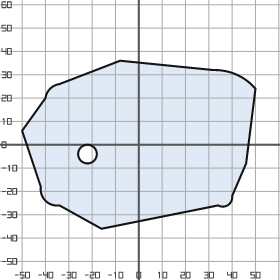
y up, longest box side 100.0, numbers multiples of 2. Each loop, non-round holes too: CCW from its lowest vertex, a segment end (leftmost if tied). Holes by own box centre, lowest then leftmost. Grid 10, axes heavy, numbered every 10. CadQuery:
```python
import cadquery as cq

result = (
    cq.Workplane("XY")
    .moveTo(-16.0, -36.0)
    .lineTo(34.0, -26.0)
    .threePointArc((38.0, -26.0), (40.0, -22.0))
    .lineTo(46.0, -8.0)
    .lineTo(50.0, 24.0)
    .threePointArc((42.0, 30.0), (32.0, 32.0))
    .lineTo(-8.0, 36.0)
    .lineTo(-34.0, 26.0)
    .threePointArc((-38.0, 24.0), (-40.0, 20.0))
    .lineTo(-50.0, 6.0)
    .lineTo(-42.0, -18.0)
    .threePointArc((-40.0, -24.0), (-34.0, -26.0))
    .close()
    .moveTo(-22.0, -4.0)
    .circle(4.0)
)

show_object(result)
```